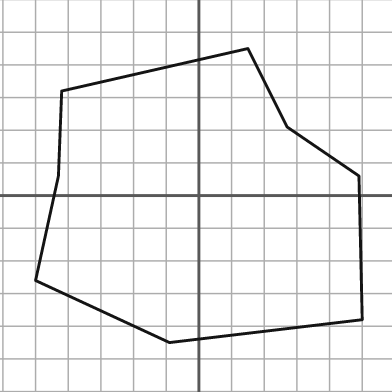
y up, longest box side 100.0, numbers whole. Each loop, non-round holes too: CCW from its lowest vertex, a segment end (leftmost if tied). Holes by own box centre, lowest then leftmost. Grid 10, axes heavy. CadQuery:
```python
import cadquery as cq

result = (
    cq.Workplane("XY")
    .moveTo(-9.0, -45.0)
    .lineTo(50.0, -38.0)
    .lineTo(49.0, 6.0)
    .lineTo(27.0, 21.0)
    .lineTo(15.0, 45.0)
    .lineTo(-42.0, 32.0)
    .lineTo(-43.0, 6.0)
    .lineTo(-50.0, -26.0)
    .close()
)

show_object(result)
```